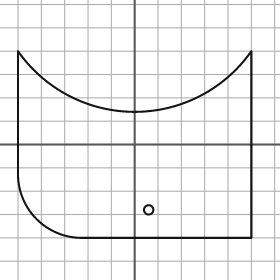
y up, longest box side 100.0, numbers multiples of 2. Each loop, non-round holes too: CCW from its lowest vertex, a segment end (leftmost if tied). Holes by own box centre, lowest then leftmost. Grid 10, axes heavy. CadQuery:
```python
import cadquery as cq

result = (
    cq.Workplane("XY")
    .moveTo(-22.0, -40.0)
    .lineTo(50.0, -40.0)
    .lineTo(50.0, 40.0)
    .threePointArc((0.0, 14.0), (-50.0, 40.0))
    .lineTo(-50.0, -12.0)
    .threePointArc((-42.0, -32.0), (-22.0, -40.0))
    .close()
    .moveTo(6.0, -28.0)
    .circle(2.0)
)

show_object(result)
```